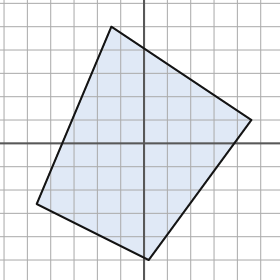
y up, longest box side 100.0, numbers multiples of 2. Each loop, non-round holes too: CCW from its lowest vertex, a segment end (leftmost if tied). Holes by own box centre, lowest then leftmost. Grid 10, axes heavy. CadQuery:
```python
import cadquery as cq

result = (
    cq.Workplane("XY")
    .moveTo(2.0, -50.0)
    .lineTo(46.0, 10.0)
    .lineTo(-14.0, 50.0)
    .lineTo(-46.0, -26.0)
    .close()
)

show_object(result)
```